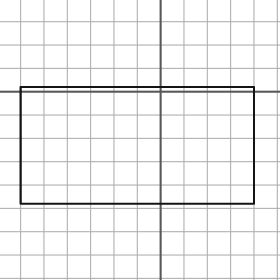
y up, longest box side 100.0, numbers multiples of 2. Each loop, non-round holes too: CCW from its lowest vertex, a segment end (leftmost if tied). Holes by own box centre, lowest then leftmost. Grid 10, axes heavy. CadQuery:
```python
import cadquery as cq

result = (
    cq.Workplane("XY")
    .moveTo(-60.0, -48.0)
    .lineTo(40.0, -48.0)
    .lineTo(40.0, 2.0)
    .lineTo(-60.0, 2.0)
    .close()
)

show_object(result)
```